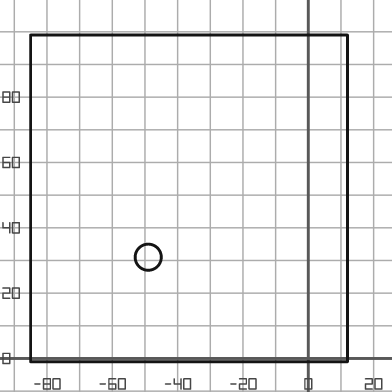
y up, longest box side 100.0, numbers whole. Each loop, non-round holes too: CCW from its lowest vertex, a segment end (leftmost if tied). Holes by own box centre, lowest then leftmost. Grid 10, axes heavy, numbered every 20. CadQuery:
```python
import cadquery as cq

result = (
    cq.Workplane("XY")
    .moveTo(-85.0, -1.0)
    .lineTo(12.0, -1.0)
    .lineTo(12.0, 99.0)
    .lineTo(-85.0, 99.0)
    .close()
    .moveTo(-49.0, 31.0)
    .circle(4.0)
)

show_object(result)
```